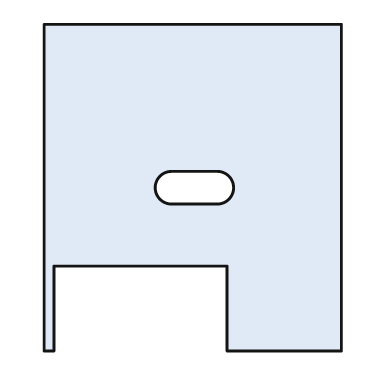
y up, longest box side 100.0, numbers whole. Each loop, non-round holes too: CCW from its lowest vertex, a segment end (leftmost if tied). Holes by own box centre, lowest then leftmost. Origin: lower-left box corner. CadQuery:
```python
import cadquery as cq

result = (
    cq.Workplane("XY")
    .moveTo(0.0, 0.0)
    .lineTo(3.0, 0.0)
    .lineTo(3.0, 26.0)
    .lineTo(56.0, 26.0)
    .lineTo(56.0, 0.0)
    .lineTo(91.0, 0.0)
    .lineTo(91.0, 100.0)
    .lineTo(0.0, 100.0)
    .close()
    .moveTo(39.0, 45.0)
    .lineTo(53.0, 45.0)
    .threePointArc((58.0, 50.0), (53.0, 55.0))
    .lineTo(39.0, 55.0)
    .threePointArc((34.0, 50.0), (39.0, 45.0))
    .close()
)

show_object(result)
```